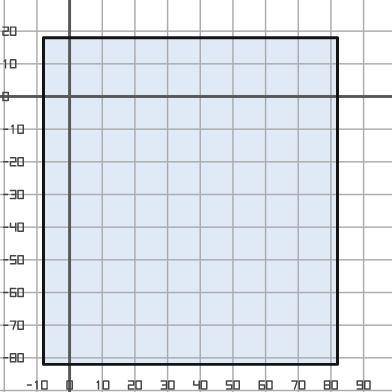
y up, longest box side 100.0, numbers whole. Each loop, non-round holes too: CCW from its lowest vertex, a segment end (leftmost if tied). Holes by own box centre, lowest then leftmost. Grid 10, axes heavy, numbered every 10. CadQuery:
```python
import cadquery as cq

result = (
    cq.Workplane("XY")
    .moveTo(-8.0, -82.0)
    .lineTo(82.0, -82.0)
    .lineTo(82.0, 18.0)
    .lineTo(-8.0, 18.0)
    .close()
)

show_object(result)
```